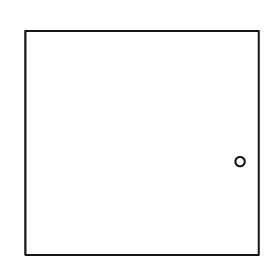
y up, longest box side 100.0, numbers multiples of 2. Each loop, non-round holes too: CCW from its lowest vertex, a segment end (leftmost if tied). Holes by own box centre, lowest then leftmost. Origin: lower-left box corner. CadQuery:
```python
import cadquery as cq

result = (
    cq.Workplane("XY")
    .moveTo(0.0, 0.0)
    .lineTo(100.0, 0.0)
    .lineTo(100.0, 96.0)
    .lineTo(0.0, 96.0)
    .close()
    .moveTo(92.0, 40.0)
    .circle(2.0)
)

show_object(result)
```